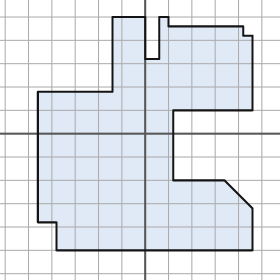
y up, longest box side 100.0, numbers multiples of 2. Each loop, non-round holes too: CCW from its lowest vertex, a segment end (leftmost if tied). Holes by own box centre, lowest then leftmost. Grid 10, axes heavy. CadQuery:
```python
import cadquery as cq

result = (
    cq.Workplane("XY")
    .moveTo(-38.0, -50.0)
    .lineTo(46.0, -50.0)
    .lineTo(46.0, -32.0)
    .lineTo(34.0, -20.0)
    .lineTo(12.0, -20.0)
    .lineTo(12.0, 10.0)
    .lineTo(46.0, 10.0)
    .lineTo(46.0, 42.0)
    .lineTo(42.0, 42.0)
    .lineTo(42.0, 46.0)
    .lineTo(10.0, 46.0)
    .lineTo(10.0, 50.0)
    .lineTo(6.0, 50.0)
    .lineTo(6.0, 32.0)
    .lineTo(0.0, 32.0)
    .lineTo(0.0, 50.0)
    .lineTo(-14.0, 50.0)
    .lineTo(-14.0, 18.0)
    .lineTo(-46.0, 18.0)
    .lineTo(-46.0, -38.0)
    .lineTo(-38.0, -38.0)
    .close()
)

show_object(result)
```